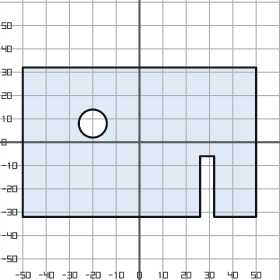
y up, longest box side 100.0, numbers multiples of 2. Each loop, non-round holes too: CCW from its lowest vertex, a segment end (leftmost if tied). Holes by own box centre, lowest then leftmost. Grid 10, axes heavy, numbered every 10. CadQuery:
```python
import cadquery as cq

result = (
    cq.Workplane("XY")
    .moveTo(-50.0, -32.0)
    .lineTo(26.0, -32.0)
    .lineTo(26.0, -6.0)
    .lineTo(32.0, -6.0)
    .lineTo(32.0, -32.0)
    .lineTo(50.0, -32.0)
    .lineTo(50.0, 32.0)
    .lineTo(-50.0, 32.0)
    .close()
    .moveTo(-20.0, 8.0)
    .circle(6.0)
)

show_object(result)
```